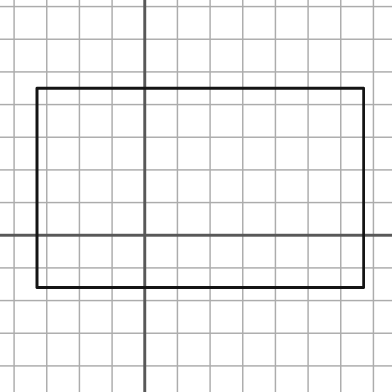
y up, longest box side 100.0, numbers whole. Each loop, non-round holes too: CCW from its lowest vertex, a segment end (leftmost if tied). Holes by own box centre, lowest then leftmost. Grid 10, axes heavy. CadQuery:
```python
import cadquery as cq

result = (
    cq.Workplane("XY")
    .moveTo(-33.0, -16.0)
    .lineTo(67.0, -16.0)
    .lineTo(67.0, 45.0)
    .lineTo(-33.0, 45.0)
    .close()
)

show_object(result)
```